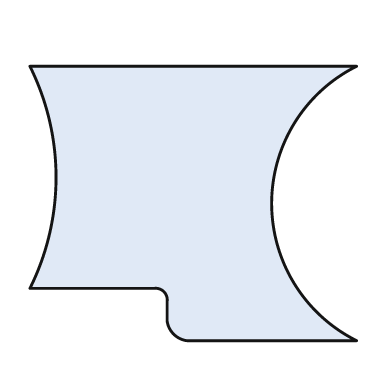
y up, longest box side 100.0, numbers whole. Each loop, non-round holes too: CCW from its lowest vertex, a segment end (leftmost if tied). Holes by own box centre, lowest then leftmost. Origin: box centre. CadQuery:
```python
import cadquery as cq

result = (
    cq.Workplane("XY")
    .moveTo(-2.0, -42.0)
    .lineTo(50.0, -42.0)
    .threePointArc((24.0, 0.0), (50.0, 42.0))
    .lineTo(-50.0, 42.0)
    .threePointArc((-42.0, 8.0), (-50.0, -26.0))
    .lineTo(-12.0, -26.0)
    .threePointArc((-9.0, -27.0), (-8.0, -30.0))
    .lineTo(-8.0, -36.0)
    .threePointArc((-6.0, -40.0), (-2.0, -42.0))
    .close()
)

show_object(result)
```